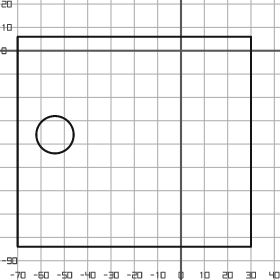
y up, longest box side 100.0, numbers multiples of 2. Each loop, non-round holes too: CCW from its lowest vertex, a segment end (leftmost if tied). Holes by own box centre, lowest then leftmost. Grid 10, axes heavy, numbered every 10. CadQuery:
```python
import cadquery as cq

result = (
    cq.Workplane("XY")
    .moveTo(-70.0, -84.0)
    .lineTo(30.0, -84.0)
    .lineTo(30.0, 6.0)
    .lineTo(-70.0, 6.0)
    .close()
    .moveTo(-54.0, -36.0)
    .circle(8.0)
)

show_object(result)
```